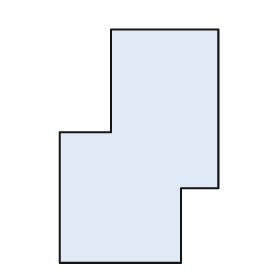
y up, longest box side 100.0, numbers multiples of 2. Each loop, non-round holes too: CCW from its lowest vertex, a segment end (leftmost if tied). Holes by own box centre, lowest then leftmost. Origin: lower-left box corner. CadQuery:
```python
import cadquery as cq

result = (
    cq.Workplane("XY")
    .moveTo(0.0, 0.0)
    .lineTo(52.0, 0.0)
    .lineTo(52.0, 32.0)
    .lineTo(68.0, 32.0)
    .lineTo(68.0, 100.0)
    .lineTo(22.0, 100.0)
    .lineTo(22.0, 56.0)
    .lineTo(0.0, 56.0)
    .close()
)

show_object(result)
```